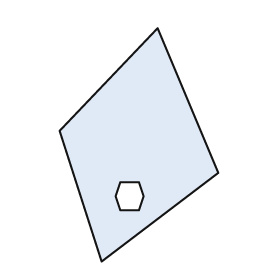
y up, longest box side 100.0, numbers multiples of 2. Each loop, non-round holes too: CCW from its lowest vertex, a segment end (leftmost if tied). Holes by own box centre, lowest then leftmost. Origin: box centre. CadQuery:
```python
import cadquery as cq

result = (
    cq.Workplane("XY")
    .moveTo(-16.0, -50.0)
    .lineTo(34.0, -12.0)
    .lineTo(8.0, 50.0)
    .lineTo(-34.0, 6.0)
    .close()
    .moveTo(-8.0, -28.0)
    .lineTo(0.0, -28.0)
    .lineTo(2.0, -22.0)
    .lineTo(0.0, -16.0)
    .lineTo(-8.0, -16.0)
    .lineTo(-10.0, -22.0)
    .close()
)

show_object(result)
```